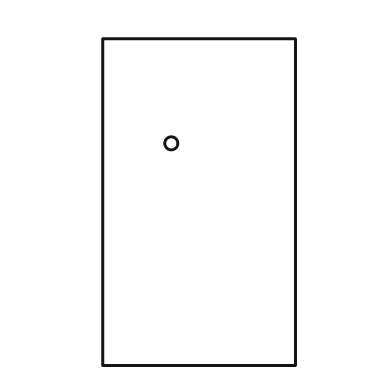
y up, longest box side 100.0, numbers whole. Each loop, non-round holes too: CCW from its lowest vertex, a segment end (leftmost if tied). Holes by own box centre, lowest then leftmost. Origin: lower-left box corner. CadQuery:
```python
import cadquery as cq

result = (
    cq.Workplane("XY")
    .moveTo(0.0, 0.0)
    .lineTo(59.0, 0.0)
    .lineTo(59.0, 100.0)
    .lineTo(0.0, 100.0)
    .close()
    .moveTo(21.0, 68.0)
    .circle(2.0)
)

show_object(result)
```